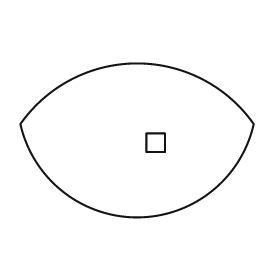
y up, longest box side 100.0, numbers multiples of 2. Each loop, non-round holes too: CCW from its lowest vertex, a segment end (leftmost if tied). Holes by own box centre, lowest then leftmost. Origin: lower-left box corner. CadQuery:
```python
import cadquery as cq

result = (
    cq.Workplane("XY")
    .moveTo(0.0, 40.0)
    .threePointArc((50.0, 0.0), (100.0, 40.0))
    .threePointArc((50.0, 66.0), (0.0, 40.0))
    .close()
    .moveTo(54.0, 28.0)
    .lineTo(62.0, 28.0)
    .lineTo(62.0, 36.0)
    .lineTo(54.0, 36.0)
    .close()
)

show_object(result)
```